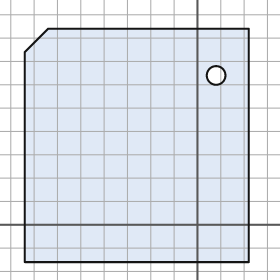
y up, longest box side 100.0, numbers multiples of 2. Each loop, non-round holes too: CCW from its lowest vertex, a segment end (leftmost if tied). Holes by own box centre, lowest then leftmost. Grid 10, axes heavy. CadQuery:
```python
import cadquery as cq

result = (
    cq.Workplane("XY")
    .moveTo(-74.0, -16.0)
    .lineTo(22.0, -16.0)
    .lineTo(22.0, 84.0)
    .lineTo(-64.0, 84.0)
    .lineTo(-74.0, 74.0)
    .close()
    .moveTo(8.0, 64.0)
    .circle(4.0)
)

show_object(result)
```